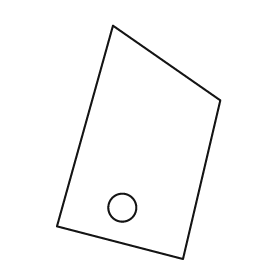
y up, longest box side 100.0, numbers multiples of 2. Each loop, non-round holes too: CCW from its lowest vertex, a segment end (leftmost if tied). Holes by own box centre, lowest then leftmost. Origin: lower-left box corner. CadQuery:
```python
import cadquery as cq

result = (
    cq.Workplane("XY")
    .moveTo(54.0, 0.0)
    .lineTo(70.0, 68.0)
    .lineTo(24.0, 100.0)
    .lineTo(0.0, 14.0)
    .close()
    .moveTo(28.0, 22.0)
    .circle(6.0)
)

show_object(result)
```